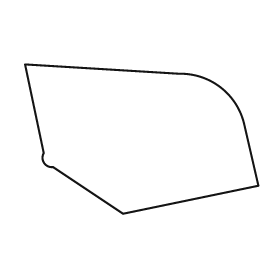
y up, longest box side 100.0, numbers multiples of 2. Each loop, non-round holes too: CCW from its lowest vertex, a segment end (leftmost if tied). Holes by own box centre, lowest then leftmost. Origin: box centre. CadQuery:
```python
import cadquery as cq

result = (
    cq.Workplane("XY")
    .moveTo(-8.0, -32.0)
    .lineTo(50.0, -20.0)
    .lineTo(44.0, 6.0)
    .threePointArc((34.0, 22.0), (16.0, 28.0))
    .lineTo(-50.0, 32.0)
    .lineTo(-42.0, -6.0)
    .threePointArc((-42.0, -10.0), (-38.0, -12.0))
    .close()
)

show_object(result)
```